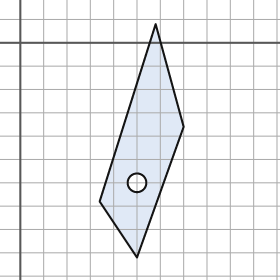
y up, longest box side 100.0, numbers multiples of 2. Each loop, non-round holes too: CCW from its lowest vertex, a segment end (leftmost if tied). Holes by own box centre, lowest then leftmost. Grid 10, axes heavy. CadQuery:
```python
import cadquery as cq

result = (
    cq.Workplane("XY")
    .moveTo(50.0, -92.0)
    .lineTo(70.0, -36.0)
    .lineTo(58.0, 8.0)
    .lineTo(34.0, -68.0)
    .close()
    .moveTo(50.0, -60.0)
    .circle(4.0)
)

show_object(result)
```